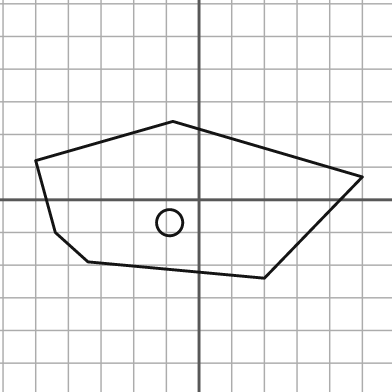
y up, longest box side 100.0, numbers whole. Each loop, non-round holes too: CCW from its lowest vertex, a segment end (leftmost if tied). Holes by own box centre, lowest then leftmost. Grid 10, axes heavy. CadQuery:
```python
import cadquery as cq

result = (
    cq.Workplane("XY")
    .moveTo(20.0, -24.0)
    .lineTo(50.0, 7.0)
    .lineTo(-8.0, 24.0)
    .lineTo(-50.0, 12.0)
    .lineTo(-44.0, -10.0)
    .lineTo(-34.0, -19.0)
    .close()
    .moveTo(-9.0, -7.0)
    .circle(4.0)
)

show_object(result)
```